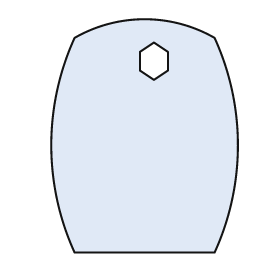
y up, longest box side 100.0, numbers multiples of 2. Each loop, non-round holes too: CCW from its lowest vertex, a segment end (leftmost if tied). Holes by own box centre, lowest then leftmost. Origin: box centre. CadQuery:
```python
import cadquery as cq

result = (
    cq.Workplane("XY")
    .moveTo(-30.0, -50.0)
    .lineTo(30.0, -50.0)
    .threePointArc((40.0, -4.0), (30.0, 42.0))
    .threePointArc((0.0, 50.0), (-30.0, 42.0))
    .threePointArc((-40.0, -4.0), (-30.0, -50.0))
    .close()
    .moveTo(4.0, 24.0)
    .lineTo(10.0, 28.0)
    .lineTo(10.0, 36.0)
    .lineTo(4.0, 40.0)
    .lineTo(-2.0, 36.0)
    .lineTo(-2.0, 28.0)
    .close()
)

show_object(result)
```